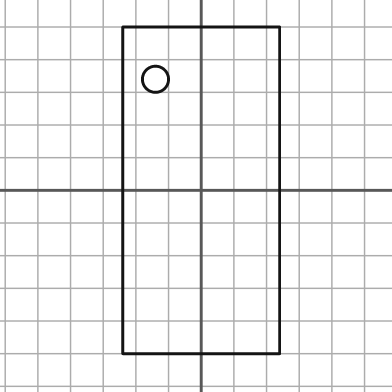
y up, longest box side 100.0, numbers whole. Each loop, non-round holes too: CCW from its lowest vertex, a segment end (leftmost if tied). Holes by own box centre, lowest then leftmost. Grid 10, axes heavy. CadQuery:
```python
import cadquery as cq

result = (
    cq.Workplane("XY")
    .moveTo(-24.0, -50.0)
    .lineTo(24.0, -50.0)
    .lineTo(24.0, 50.0)
    .lineTo(-24.0, 50.0)
    .close()
    .moveTo(-14.0, 34.0)
    .circle(4.0)
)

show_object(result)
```